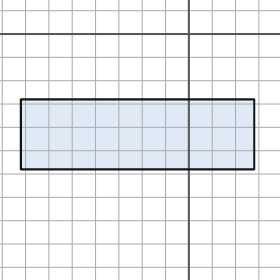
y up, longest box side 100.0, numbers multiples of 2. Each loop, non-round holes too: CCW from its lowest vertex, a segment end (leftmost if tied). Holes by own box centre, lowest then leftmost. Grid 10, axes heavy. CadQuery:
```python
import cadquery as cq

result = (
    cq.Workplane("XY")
    .moveTo(-72.0, -58.0)
    .lineTo(28.0, -58.0)
    .lineTo(28.0, -28.0)
    .lineTo(-72.0, -28.0)
    .close()
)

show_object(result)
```